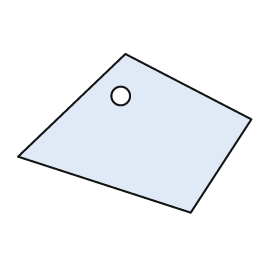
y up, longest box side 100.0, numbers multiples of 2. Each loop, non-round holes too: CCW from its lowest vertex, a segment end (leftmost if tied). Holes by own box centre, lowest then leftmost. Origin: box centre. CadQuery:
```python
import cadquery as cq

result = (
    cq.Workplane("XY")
    .moveTo(24.0, -34.0)
    .lineTo(50.0, 6.0)
    .lineTo(-4.0, 34.0)
    .lineTo(-50.0, -10.0)
    .close()
    .moveTo(-6.0, 16.0)
    .circle(4.0)
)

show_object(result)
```